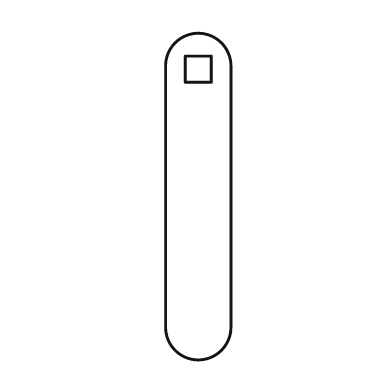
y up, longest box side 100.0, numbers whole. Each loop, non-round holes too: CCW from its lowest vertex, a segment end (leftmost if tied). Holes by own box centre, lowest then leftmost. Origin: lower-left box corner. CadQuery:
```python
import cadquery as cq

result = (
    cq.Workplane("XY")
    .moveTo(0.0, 10.0)
    .threePointArc((10.0, 0.0), (20.0, 10.0))
    .lineTo(20.0, 90.0)
    .threePointArc((10.0, 100.0), (0.0, 90.0))
    .close()
    .moveTo(6.0, 85.0)
    .lineTo(14.0, 85.0)
    .lineTo(14.0, 93.0)
    .lineTo(6.0, 93.0)
    .close()
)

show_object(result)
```